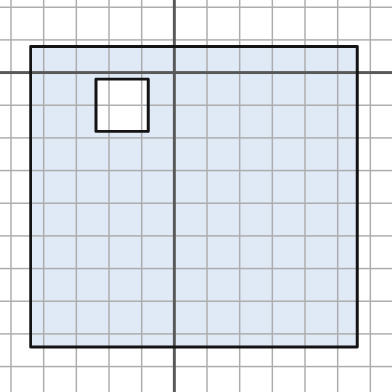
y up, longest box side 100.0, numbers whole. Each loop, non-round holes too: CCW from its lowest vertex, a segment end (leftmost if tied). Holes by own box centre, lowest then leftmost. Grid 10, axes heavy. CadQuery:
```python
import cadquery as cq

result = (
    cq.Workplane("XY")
    .moveTo(-44.0, -84.0)
    .lineTo(56.0, -84.0)
    .lineTo(56.0, 8.0)
    .lineTo(-44.0, 8.0)
    .close()
    .moveTo(-24.0, -18.0)
    .lineTo(-8.0, -18.0)
    .lineTo(-8.0, -2.0)
    .lineTo(-24.0, -2.0)
    .close()
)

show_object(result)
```